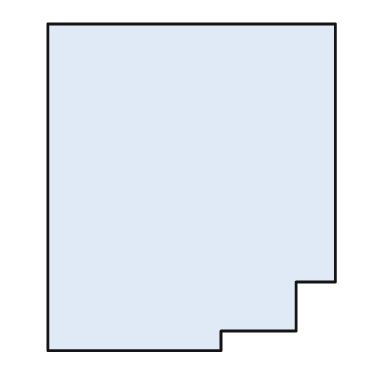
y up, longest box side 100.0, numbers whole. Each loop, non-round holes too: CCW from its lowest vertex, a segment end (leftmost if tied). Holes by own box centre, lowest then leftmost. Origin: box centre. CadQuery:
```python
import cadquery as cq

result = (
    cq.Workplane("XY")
    .moveTo(-44.0, -50.0)
    .lineTo(9.0, -50.0)
    .lineTo(9.0, -44.0)
    .lineTo(32.0, -44.0)
    .lineTo(32.0, -29.0)
    .lineTo(44.0, -29.0)
    .lineTo(44.0, 50.0)
    .lineTo(-44.0, 50.0)
    .close()
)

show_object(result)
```